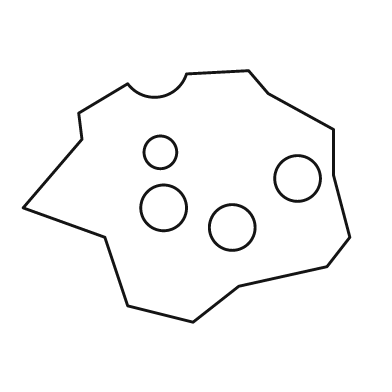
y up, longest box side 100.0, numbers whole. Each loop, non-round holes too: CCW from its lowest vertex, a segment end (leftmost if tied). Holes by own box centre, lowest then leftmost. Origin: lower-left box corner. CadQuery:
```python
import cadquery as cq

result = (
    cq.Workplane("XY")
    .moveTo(52.0, 0.0)
    .lineTo(66.0, 11.0)
    .lineTo(93.0, 17.0)
    .lineTo(100.0, 26.0)
    .lineTo(95.0, 45.0)
    .lineTo(95.0, 59.0)
    .lineTo(75.0, 70.0)
    .lineTo(69.0, 77.0)
    .lineTo(50.0, 76.0)
    .threePointArc((42.0, 69.0), (32.0, 73.0))
    .lineTo(17.0, 64.0)
    .lineTo(18.0, 56.0)
    .lineTo(0.0, 35.0)
    .lineTo(25.0, 26.0)
    .lineTo(32.0, 5.0)
    .close()
    .moveTo(64.0, 29.0)
    .circle(7.0)
    .moveTo(43.0, 35.0)
    .circle(7.0)
    .moveTo(84.0, 44.0)
    .circle(7.0)
    .moveTo(42.0, 52.0)
    .circle(5.0)
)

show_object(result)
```